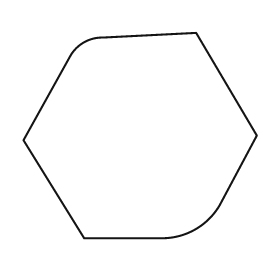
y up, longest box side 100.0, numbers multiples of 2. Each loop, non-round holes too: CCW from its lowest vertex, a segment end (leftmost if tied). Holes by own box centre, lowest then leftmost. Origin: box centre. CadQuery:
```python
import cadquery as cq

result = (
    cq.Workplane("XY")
    .moveTo(-24.0, -44.0)
    .lineTo(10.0, -44.0)
    .threePointArc((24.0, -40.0), (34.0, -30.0))
    .lineTo(50.0, 0.0)
    .lineTo(24.0, 44.0)
    .lineTo(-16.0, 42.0)
    .threePointArc((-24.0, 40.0), (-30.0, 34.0))
    .lineTo(-50.0, -2.0)
    .close()
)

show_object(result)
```